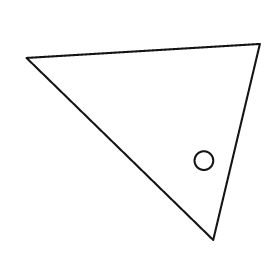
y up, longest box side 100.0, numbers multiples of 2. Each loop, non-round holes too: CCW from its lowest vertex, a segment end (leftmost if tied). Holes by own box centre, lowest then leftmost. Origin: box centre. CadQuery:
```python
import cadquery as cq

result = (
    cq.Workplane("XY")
    .moveTo(30.0, -42.0)
    .lineTo(50.0, 42.0)
    .lineTo(-50.0, 36.0)
    .close()
    .moveTo(26.0, -8.0)
    .circle(4.0)
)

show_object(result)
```